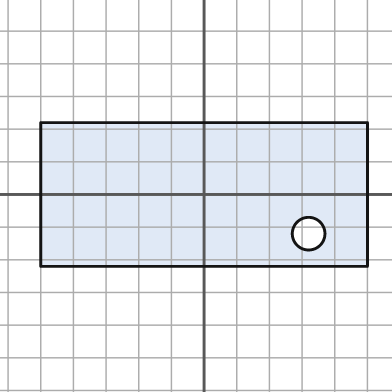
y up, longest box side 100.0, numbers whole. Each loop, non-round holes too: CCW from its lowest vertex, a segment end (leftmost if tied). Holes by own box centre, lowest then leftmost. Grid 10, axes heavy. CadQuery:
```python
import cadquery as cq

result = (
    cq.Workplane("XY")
    .moveTo(-50.0, -22.0)
    .lineTo(50.0, -22.0)
    .lineTo(50.0, 22.0)
    .lineTo(-50.0, 22.0)
    .close()
    .moveTo(32.0, -12.0)
    .circle(5.0)
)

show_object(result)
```